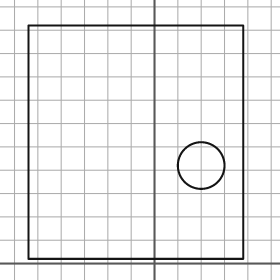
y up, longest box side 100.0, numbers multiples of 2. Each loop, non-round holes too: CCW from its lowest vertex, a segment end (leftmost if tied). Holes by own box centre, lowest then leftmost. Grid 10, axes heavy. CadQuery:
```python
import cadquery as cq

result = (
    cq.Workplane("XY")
    .moveTo(-54.0, 2.0)
    .lineTo(38.0, 2.0)
    .lineTo(38.0, 102.0)
    .lineTo(-54.0, 102.0)
    .close()
    .moveTo(20.0, 42.0)
    .circle(10.0)
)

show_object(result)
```